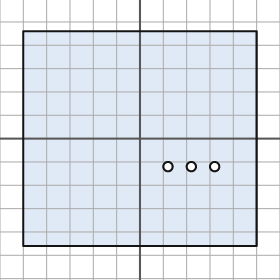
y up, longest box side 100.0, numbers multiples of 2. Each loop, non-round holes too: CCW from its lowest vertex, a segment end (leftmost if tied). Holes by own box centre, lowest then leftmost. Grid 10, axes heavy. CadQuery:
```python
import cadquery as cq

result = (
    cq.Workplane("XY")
    .moveTo(-50.0, -46.0)
    .lineTo(50.0, -46.0)
    .lineTo(50.0, 46.0)
    .lineTo(-50.0, 46.0)
    .close()
    .moveTo(12.0, -12.0)
    .circle(2.0)
    .moveTo(22.0, -12.0)
    .circle(2.0)
    .moveTo(32.0, -12.0)
    .circle(2.0)
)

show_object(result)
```